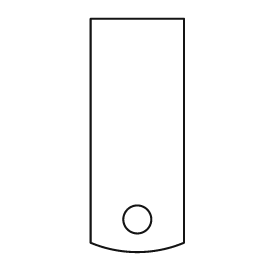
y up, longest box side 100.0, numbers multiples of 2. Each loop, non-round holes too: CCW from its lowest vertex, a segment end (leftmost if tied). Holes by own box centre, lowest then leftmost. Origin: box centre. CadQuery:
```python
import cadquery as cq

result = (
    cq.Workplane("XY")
    .moveTo(-20.0, -46.0)
    .threePointArc((0.0, -50.0), (20.0, -46.0))
    .lineTo(20.0, 50.0)
    .lineTo(-20.0, 50.0)
    .close()
    .moveTo(0.0, -36.0)
    .circle(6.0)
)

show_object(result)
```